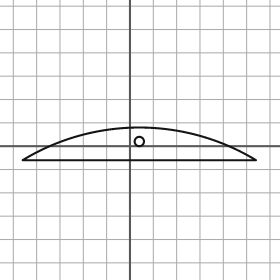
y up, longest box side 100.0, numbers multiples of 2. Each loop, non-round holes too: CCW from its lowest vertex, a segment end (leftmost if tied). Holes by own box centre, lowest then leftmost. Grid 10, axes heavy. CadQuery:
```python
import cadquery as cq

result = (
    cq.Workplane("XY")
    .moveTo(-46.0, -6.0)
    .lineTo(54.0, -6.0)
    .threePointArc((4.0, 8.0), (-46.0, -6.0))
    .close()
    .moveTo(4.0, 2.0)
    .circle(2.0)
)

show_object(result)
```